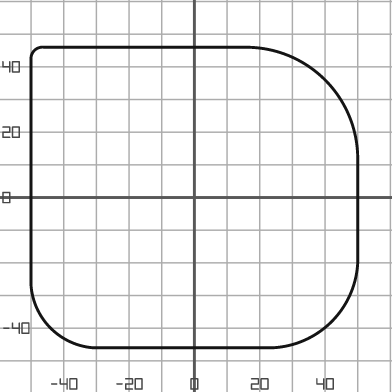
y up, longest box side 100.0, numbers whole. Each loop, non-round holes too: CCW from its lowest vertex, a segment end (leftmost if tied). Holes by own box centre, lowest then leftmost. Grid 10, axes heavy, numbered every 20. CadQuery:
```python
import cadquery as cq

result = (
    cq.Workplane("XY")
    .moveTo(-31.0, -46.0)
    .lineTo(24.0, -46.0)
    .threePointArc((42.0, -38.0), (50.0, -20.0))
    .lineTo(50.0, 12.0)
    .threePointArc((40.0, 36.0), (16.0, 46.0))
    .lineTo(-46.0, 46.0)
    .threePointArc((-49.0, 45.0), (-50.0, 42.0))
    .lineTo(-50.0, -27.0)
    .threePointArc((-44.0, -40.0), (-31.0, -46.0))
    .close()
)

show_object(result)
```